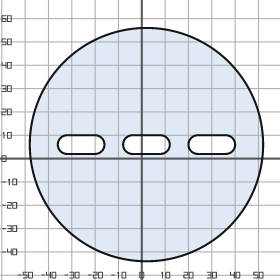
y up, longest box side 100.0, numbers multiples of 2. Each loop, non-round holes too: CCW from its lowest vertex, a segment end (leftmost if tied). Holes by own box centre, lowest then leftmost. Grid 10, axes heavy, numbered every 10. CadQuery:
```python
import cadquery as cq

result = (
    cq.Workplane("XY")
    .moveTo(2.0, 6.0)
    .circle(50.0)
    .moveTo(-32.0, 2.0)
    .lineTo(-20.0, 2.0)
    .threePointArc((-16.0, 6.0), (-20.0, 10.0))
    .lineTo(-32.0, 10.0)
    .threePointArc((-36.0, 6.0), (-32.0, 2.0))
    .close()
    .moveTo(-4.0, 2.0)
    .lineTo(8.0, 2.0)
    .threePointArc((12.0, 6.0), (8.0, 10.0))
    .lineTo(-4.0, 10.0)
    .threePointArc((-8.0, 6.0), (-4.0, 2.0))
    .close()
    .moveTo(24.0, 2.0)
    .lineTo(36.0, 2.0)
    .threePointArc((40.0, 6.0), (36.0, 10.0))
    .lineTo(24.0, 10.0)
    .threePointArc((20.0, 6.0), (24.0, 2.0))
    .close()
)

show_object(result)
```